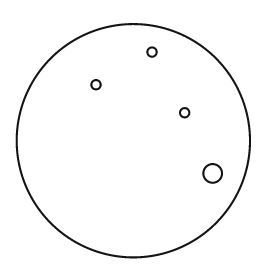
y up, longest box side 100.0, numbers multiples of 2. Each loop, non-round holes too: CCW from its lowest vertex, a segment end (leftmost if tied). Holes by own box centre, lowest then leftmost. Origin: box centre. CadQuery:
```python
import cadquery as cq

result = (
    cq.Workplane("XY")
    .moveTo(0.0, 0.0)
    .circle(50.0)
    .moveTo(34.0, -14.0)
    .circle(4.0)
    .moveTo(22.0, 12.0)
    .circle(2.0)
    .moveTo(-16.0, 24.0)
    .circle(2.0)
    .moveTo(8.0, 38.0)
    .circle(2.0)
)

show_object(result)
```